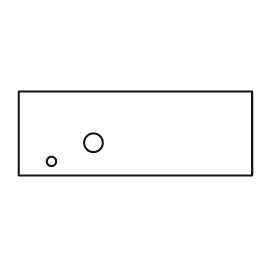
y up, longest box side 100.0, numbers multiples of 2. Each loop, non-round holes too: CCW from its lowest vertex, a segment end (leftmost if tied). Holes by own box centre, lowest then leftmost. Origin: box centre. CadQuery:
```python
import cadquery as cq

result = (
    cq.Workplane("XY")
    .moveTo(-50.0, -18.0)
    .lineTo(50.0, -18.0)
    .lineTo(50.0, 18.0)
    .lineTo(-50.0, 18.0)
    .close()
    .moveTo(-36.0, -12.0)
    .circle(2.0)
    .moveTo(-18.0, -4.0)
    .circle(4.0)
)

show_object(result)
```